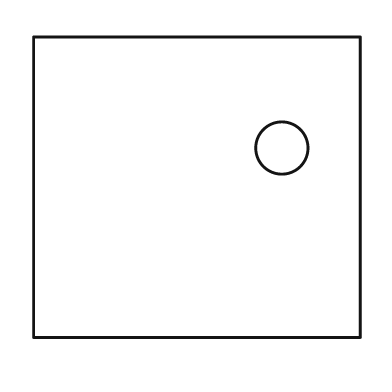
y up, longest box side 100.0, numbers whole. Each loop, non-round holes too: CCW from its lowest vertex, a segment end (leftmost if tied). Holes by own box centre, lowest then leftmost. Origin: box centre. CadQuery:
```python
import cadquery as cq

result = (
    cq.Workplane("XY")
    .moveTo(-50.0, -46.0)
    .lineTo(50.0, -46.0)
    .lineTo(50.0, 46.0)
    .lineTo(-50.0, 46.0)
    .close()
    .moveTo(26.0, 12.0)
    .circle(8.0)
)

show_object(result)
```